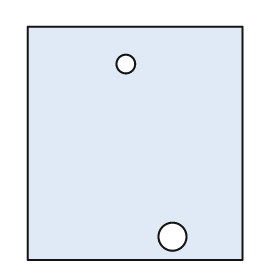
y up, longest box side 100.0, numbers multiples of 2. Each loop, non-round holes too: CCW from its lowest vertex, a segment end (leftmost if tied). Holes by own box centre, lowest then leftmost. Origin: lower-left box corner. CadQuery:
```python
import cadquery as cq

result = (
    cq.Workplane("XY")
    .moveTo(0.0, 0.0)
    .lineTo(92.0, 0.0)
    .lineTo(92.0, 100.0)
    .lineTo(0.0, 100.0)
    .close()
    .moveTo(62.0, 10.0)
    .circle(6.0)
    .moveTo(42.0, 84.0)
    .circle(4.0)
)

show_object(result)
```